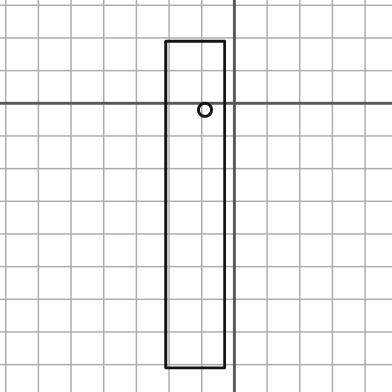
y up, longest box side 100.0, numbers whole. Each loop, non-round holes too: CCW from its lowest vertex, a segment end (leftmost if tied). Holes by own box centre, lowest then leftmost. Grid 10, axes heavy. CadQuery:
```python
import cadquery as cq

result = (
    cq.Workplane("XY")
    .moveTo(-21.0, -81.0)
    .lineTo(-3.0, -81.0)
    .lineTo(-3.0, 19.0)
    .lineTo(-21.0, 19.0)
    .close()
    .moveTo(-9.0, -2.0)
    .circle(2.0)
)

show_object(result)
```